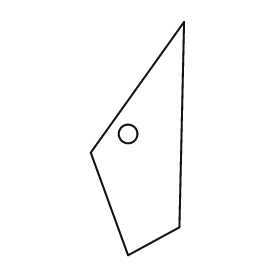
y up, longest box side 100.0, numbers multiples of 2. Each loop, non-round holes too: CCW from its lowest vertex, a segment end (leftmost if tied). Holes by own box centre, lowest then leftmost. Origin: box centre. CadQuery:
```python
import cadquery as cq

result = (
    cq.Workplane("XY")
    .moveTo(-4.0, -50.0)
    .lineTo(18.0, -38.0)
    .lineTo(20.0, 50.0)
    .lineTo(-20.0, -6.0)
    .close()
    .moveTo(-4.0, 2.0)
    .circle(4.0)
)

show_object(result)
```